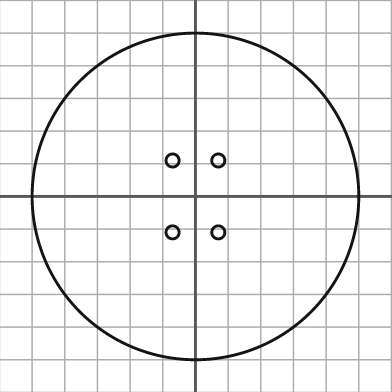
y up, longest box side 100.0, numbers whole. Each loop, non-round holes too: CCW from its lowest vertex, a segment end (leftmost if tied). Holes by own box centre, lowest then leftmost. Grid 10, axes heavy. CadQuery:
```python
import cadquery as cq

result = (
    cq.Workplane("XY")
    .moveTo(0.0, 0.0)
    .circle(50.0)
    .moveTo(-7.0, -11.0)
    .circle(2.0)
    .moveTo(7.0, -11.0)
    .circle(2.0)
    .moveTo(-7.0, 11.0)
    .circle(2.0)
    .moveTo(7.0, 11.0)
    .circle(2.0)
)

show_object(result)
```